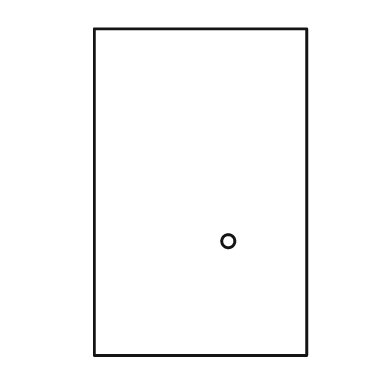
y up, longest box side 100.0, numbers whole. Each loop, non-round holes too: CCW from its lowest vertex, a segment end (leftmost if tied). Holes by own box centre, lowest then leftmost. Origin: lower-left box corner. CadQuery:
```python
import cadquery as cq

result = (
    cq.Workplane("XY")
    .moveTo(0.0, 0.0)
    .lineTo(65.0, 0.0)
    .lineTo(65.0, 100.0)
    .lineTo(0.0, 100.0)
    .close()
    .moveTo(41.0, 35.0)
    .circle(2.0)
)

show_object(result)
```